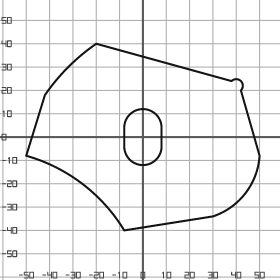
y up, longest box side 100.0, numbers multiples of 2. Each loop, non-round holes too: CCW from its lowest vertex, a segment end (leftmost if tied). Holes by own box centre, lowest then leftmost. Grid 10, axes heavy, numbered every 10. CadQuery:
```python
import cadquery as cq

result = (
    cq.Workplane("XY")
    .moveTo(-8.0, -40.0)
    .lineTo(30.0, -34.0)
    .threePointArc((44.0, -24.0), (50.0, -8.0))
    .lineTo(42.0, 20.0)
    .threePointArc((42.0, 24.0), (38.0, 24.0))
    .lineTo(-20.0, 40.0)
    .threePointArc((-32.0, 30.0), (-42.0, 18.0))
    .lineTo(-50.0, -8.0)
    .threePointArc((-26.0, -20.0), (-8.0, -40.0))
    .close()
    .moveTo(-8.0, -4.0)
    .threePointArc((0.0, -12.0), (8.0, -4.0))
    .lineTo(8.0, 4.0)
    .threePointArc((0.0, 12.0), (-8.0, 4.0))
    .close()
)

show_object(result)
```